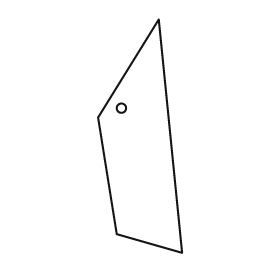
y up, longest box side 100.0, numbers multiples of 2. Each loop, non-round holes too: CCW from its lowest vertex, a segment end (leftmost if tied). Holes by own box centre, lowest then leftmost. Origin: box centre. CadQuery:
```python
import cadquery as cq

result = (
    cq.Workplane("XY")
    .moveTo(18.0, -50.0)
    .lineTo(8.0, 50.0)
    .lineTo(-18.0, 8.0)
    .lineTo(-10.0, -42.0)
    .close()
    .moveTo(-8.0, 12.0)
    .circle(2.0)
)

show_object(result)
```